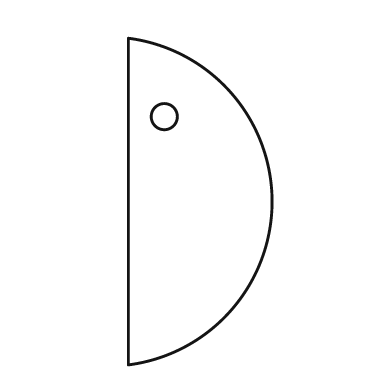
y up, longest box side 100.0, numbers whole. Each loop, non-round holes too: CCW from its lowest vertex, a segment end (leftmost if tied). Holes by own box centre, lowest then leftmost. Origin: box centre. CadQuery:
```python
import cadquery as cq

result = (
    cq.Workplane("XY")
    .moveTo(-22.0, -50.0)
    .threePointArc((22.0, 0.0), (-22.0, 50.0))
    .close()
    .moveTo(-11.0, 26.0)
    .circle(4.0)
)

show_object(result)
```